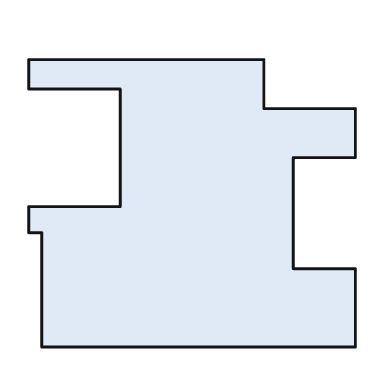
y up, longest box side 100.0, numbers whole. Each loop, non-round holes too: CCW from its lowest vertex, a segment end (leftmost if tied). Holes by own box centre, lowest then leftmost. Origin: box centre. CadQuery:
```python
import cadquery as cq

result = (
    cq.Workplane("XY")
    .moveTo(-46.0, -44.0)
    .lineTo(50.0, -44.0)
    .lineTo(50.0, -20.0)
    .lineTo(31.0, -20.0)
    .lineTo(31.0, 14.0)
    .lineTo(50.0, 14.0)
    .lineTo(50.0, 29.0)
    .lineTo(22.0, 29.0)
    .lineTo(22.0, 44.0)
    .lineTo(-50.0, 44.0)
    .lineTo(-50.0, 35.0)
    .lineTo(-22.0, 35.0)
    .lineTo(-22.0, -1.0)
    .lineTo(-50.0, -1.0)
    .lineTo(-50.0, -9.0)
    .lineTo(-46.0, -9.0)
    .close()
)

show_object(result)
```